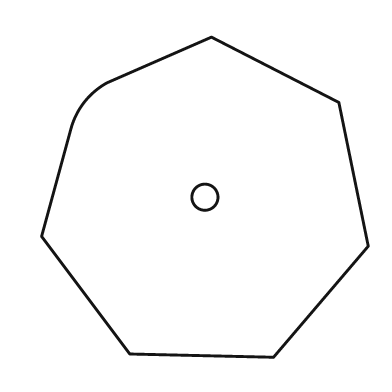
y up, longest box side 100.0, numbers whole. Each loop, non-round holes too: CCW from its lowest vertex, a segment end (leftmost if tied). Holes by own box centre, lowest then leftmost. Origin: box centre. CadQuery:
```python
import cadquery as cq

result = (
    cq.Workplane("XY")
    .moveTo(21.0, -49.0)
    .lineTo(50.0, -15.0)
    .lineTo(41.0, 29.0)
    .lineTo(2.0, 49.0)
    .lineTo(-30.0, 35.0)
    .threePointArc((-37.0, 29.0), (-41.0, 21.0))
    .lineTo(-50.0, -12.0)
    .lineTo(-23.0, -48.0)
    .close()
    .moveTo(0.0, 0.0)
    .circle(4.0)
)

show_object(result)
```